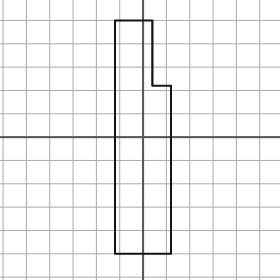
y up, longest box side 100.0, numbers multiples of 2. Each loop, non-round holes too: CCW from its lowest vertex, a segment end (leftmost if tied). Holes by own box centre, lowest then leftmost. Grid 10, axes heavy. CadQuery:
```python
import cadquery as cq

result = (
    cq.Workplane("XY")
    .moveTo(-12.0, -50.0)
    .lineTo(12.0, -50.0)
    .lineTo(12.0, 22.0)
    .lineTo(4.0, 22.0)
    .lineTo(4.0, 50.0)
    .lineTo(-12.0, 50.0)
    .close()
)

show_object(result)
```